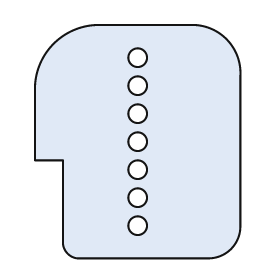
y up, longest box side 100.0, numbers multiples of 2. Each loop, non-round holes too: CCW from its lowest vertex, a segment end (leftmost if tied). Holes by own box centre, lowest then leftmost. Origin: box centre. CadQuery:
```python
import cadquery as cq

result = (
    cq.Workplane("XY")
    .moveTo(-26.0, -50.0)
    .lineTo(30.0, -50.0)
    .threePointArc((40.0, -46.0), (44.0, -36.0))
    .lineTo(44.0, 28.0)
    .threePointArc((38.0, 44.0), (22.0, 50.0))
    .lineTo(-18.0, 50.0)
    .threePointArc((-36.0, 42.0), (-44.0, 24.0))
    .lineTo(-44.0, -8.0)
    .lineTo(-32.0, -8.0)
    .lineTo(-32.0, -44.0)
    .threePointArc((-30.0, -48.0), (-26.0, -50.0))
    .close()
    .moveTo(0.0, -36.0)
    .circle(4.0)
    .moveTo(0.0, -24.0)
    .circle(4.0)
    .moveTo(0.0, -12.0)
    .circle(4.0)
    .moveTo(0.0, 0.0)
    .circle(4.0)
    .moveTo(0.0, 12.0)
    .circle(4.0)
    .moveTo(0.0, 24.0)
    .circle(4.0)
    .moveTo(0.0, 36.0)
    .circle(4.0)
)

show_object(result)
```